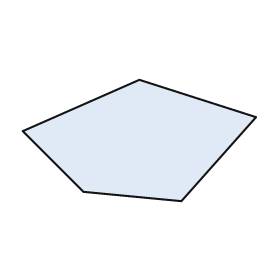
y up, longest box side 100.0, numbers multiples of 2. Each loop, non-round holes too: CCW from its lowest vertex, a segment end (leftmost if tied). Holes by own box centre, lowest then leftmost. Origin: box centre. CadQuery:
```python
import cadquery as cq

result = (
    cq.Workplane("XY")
    .moveTo(18.0, -26.0)
    .lineTo(50.0, 10.0)
    .lineTo(0.0, 26.0)
    .lineTo(-50.0, 4.0)
    .lineTo(-24.0, -22.0)
    .close()
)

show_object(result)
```